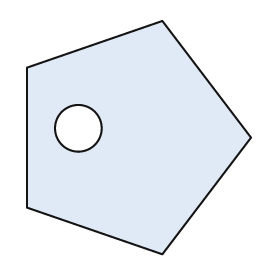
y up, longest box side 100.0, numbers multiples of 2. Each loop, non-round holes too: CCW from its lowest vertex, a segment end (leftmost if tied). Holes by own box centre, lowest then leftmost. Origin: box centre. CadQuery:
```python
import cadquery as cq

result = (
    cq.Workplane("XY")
    .moveTo(10.0, -50.0)
    .lineTo(48.0, 0.0)
    .lineTo(10.0, 50.0)
    .lineTo(-48.0, 30.0)
    .lineTo(-48.0, -30.0)
    .close()
    .moveTo(-26.0, 4.0)
    .circle(10.0)
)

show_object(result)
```